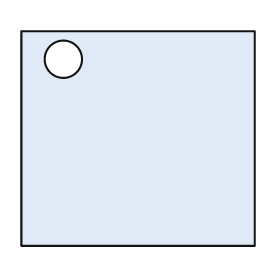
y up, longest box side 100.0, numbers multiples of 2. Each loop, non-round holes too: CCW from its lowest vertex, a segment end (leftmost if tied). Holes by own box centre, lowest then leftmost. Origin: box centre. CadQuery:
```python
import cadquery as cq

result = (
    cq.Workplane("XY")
    .moveTo(-50.0, -46.0)
    .lineTo(50.0, -46.0)
    .lineTo(50.0, 46.0)
    .lineTo(-50.0, 46.0)
    .close()
    .moveTo(-32.0, 34.0)
    .circle(8.0)
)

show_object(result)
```